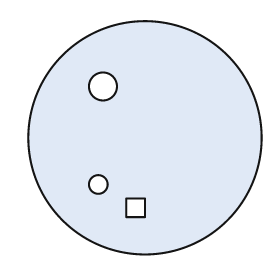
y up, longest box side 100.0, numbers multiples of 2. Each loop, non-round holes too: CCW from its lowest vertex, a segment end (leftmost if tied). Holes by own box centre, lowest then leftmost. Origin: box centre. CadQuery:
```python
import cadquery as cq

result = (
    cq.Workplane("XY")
    .moveTo(0.0, 0.0)
    .circle(50.0)
    .moveTo(-8.0, -34.0)
    .lineTo(0.0, -34.0)
    .lineTo(0.0, -26.0)
    .lineTo(-8.0, -26.0)
    .close()
    .moveTo(-20.0, -20.0)
    .circle(4.0)
    .moveTo(-18.0, 22.0)
    .circle(6.0)
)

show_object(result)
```